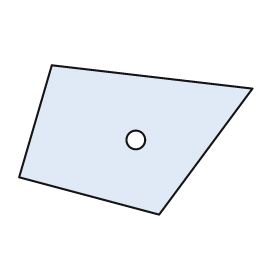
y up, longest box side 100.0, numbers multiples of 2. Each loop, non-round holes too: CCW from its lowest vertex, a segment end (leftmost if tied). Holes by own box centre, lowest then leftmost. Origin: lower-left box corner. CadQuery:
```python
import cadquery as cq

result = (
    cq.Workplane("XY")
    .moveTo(60.0, 0.0)
    .lineTo(100.0, 54.0)
    .lineTo(14.0, 64.0)
    .lineTo(0.0, 16.0)
    .close()
    .moveTo(50.0, 32.0)
    .circle(4.0)
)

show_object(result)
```